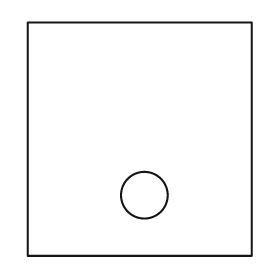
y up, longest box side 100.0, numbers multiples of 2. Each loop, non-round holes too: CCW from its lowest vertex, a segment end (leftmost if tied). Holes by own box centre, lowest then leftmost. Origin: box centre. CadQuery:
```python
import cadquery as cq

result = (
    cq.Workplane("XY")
    .moveTo(-48.0, -50.0)
    .lineTo(48.0, -50.0)
    .lineTo(48.0, 50.0)
    .lineTo(-48.0, 50.0)
    .close()
    .moveTo(2.0, -24.0)
    .circle(10.0)
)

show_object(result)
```